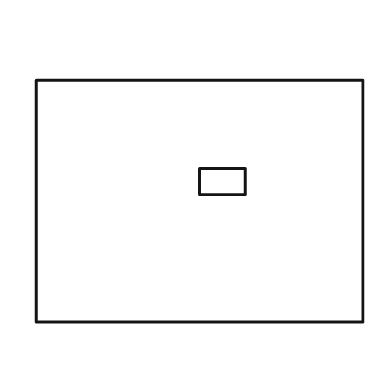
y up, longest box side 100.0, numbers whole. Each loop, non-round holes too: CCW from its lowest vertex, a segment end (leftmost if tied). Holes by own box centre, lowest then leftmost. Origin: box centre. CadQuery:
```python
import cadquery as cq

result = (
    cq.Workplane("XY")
    .moveTo(-50.0, -37.0)
    .lineTo(50.0, -37.0)
    .lineTo(50.0, 37.0)
    .lineTo(-50.0, 37.0)
    .close()
    .moveTo(0.0, 2.0)
    .lineTo(14.0, 2.0)
    .lineTo(14.0, 10.0)
    .lineTo(0.0, 10.0)
    .close()
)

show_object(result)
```